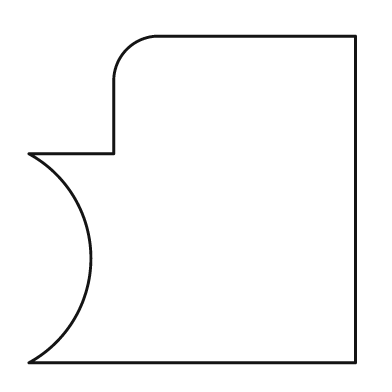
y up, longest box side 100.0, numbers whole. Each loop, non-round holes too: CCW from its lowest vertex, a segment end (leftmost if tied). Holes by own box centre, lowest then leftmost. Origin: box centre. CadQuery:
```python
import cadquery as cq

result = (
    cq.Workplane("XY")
    .moveTo(-50.0, -50.0)
    .lineTo(50.0, -50.0)
    .lineTo(50.0, 50.0)
    .lineTo(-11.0, 50.0)
    .threePointArc((-20.0, 46.0), (-24.0, 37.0))
    .lineTo(-24.0, 14.0)
    .lineTo(-50.0, 14.0)
    .threePointArc((-31.0, -18.0), (-50.0, -50.0))
    .close()
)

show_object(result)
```